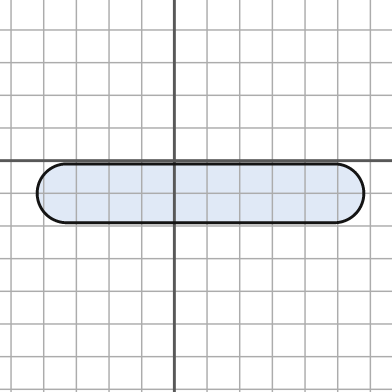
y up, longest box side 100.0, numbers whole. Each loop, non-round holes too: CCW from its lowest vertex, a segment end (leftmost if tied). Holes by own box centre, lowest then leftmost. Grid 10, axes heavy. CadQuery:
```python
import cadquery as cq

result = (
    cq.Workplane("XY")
    .moveTo(-33.0, -19.0)
    .lineTo(49.0, -19.0)
    .threePointArc((58.0, -10.0), (49.0, -1.0))
    .lineTo(-33.0, -1.0)
    .threePointArc((-42.0, -10.0), (-33.0, -19.0))
    .close()
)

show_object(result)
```